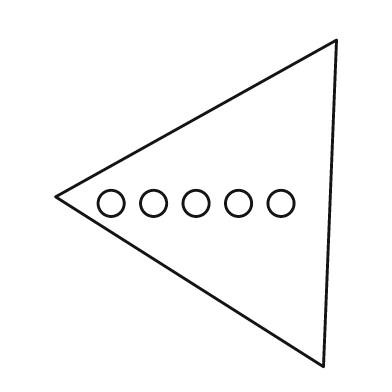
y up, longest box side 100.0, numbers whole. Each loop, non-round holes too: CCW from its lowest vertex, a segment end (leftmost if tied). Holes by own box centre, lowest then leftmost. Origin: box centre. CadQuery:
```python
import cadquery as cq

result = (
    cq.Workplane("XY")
    .moveTo(39.0, -50.0)
    .lineTo(43.0, 50.0)
    .lineTo(-43.0, 2.0)
    .close()
    .moveTo(-26.0, 0.0)
    .circle(4.0)
    .moveTo(-13.0, 0.0)
    .circle(4.0)
    .moveTo(0.0, 0.0)
    .circle(4.0)
    .moveTo(13.0, 0.0)
    .circle(4.0)
    .moveTo(26.0, 0.0)
    .circle(4.0)
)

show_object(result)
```